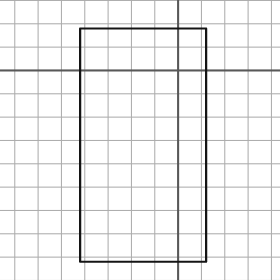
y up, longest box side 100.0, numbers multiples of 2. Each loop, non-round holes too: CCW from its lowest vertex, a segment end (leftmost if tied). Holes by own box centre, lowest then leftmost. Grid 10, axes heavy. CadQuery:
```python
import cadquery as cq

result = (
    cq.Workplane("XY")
    .moveTo(-42.0, -82.0)
    .lineTo(12.0, -82.0)
    .lineTo(12.0, 18.0)
    .lineTo(-42.0, 18.0)
    .close()
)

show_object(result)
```